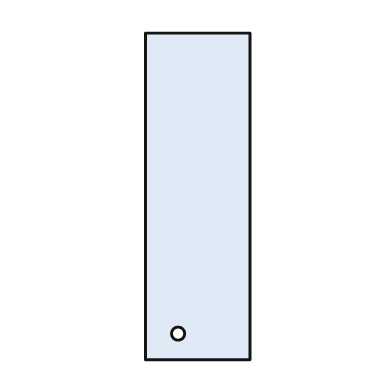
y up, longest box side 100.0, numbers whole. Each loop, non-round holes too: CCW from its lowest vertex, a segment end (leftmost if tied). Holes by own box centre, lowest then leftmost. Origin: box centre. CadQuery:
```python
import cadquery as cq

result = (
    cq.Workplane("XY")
    .moveTo(-16.0, -50.0)
    .lineTo(16.0, -50.0)
    .lineTo(16.0, 50.0)
    .lineTo(-16.0, 50.0)
    .close()
    .moveTo(-6.0, -42.0)
    .circle(2.0)
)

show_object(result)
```